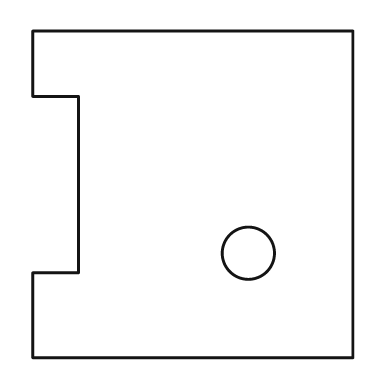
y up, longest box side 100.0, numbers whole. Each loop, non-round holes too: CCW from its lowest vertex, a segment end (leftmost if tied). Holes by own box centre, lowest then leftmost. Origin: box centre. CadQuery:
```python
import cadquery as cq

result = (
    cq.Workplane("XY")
    .moveTo(-49.0, -50.0)
    .lineTo(49.0, -50.0)
    .lineTo(49.0, 50.0)
    .lineTo(-49.0, 50.0)
    .lineTo(-49.0, 30.0)
    .lineTo(-35.0, 30.0)
    .lineTo(-35.0, -24.0)
    .lineTo(-49.0, -24.0)
    .close()
    .moveTo(17.0, -18.0)
    .circle(8.0)
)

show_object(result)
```